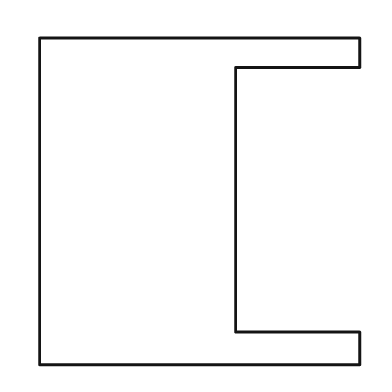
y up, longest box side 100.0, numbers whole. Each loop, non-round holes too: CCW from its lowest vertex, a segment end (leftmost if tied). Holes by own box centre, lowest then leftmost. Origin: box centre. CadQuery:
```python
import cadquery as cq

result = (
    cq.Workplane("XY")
    .moveTo(-49.0, -50.0)
    .lineTo(49.0, -50.0)
    .lineTo(49.0, -40.0)
    .lineTo(11.0, -40.0)
    .lineTo(11.0, 41.0)
    .lineTo(49.0, 41.0)
    .lineTo(49.0, 50.0)
    .lineTo(-49.0, 50.0)
    .close()
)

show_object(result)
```